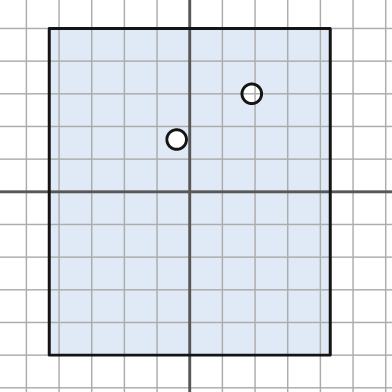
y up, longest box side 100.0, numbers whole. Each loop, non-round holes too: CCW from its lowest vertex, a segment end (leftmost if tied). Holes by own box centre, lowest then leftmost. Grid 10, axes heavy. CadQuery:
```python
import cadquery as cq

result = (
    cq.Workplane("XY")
    .moveTo(-43.0, -50.0)
    .lineTo(43.0, -50.0)
    .lineTo(43.0, 50.0)
    .lineTo(-43.0, 50.0)
    .close()
    .moveTo(-4.0, 16.0)
    .circle(3.0)
    .moveTo(19.0, 30.0)
    .circle(3.0)
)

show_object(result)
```